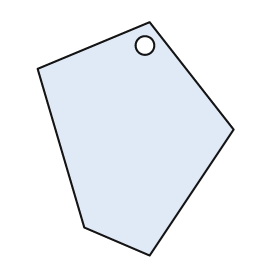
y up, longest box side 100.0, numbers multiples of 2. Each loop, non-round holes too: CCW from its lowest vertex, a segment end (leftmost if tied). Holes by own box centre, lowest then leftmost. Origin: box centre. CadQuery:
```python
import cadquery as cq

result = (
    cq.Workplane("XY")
    .moveTo(6.0, -50.0)
    .lineTo(42.0, 4.0)
    .lineTo(6.0, 50.0)
    .lineTo(-42.0, 30.0)
    .lineTo(-22.0, -38.0)
    .close()
    .moveTo(4.0, 40.0)
    .circle(4.0)
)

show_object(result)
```